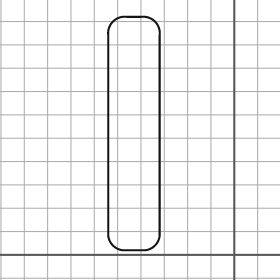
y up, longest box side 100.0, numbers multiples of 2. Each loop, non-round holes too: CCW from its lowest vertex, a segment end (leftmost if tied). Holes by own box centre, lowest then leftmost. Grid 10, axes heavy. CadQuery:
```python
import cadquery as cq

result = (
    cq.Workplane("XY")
    .moveTo(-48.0, 2.0)
    .lineTo(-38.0, 2.0)
    .threePointArc((-34.0, 4.0), (-32.0, 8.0))
    .lineTo(-32.0, 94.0)
    .threePointArc((-34.0, 100.0), (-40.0, 102.0))
    .lineTo(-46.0, 102.0)
    .threePointArc((-52.0, 100.0), (-54.0, 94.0))
    .lineTo(-54.0, 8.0)
    .threePointArc((-52.0, 4.0), (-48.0, 2.0))
    .close()
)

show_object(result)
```